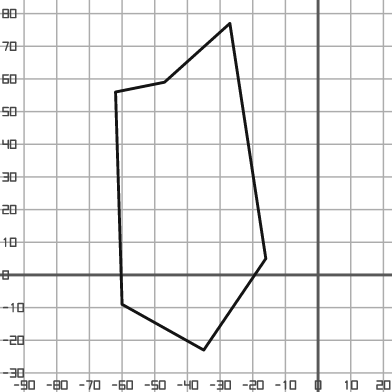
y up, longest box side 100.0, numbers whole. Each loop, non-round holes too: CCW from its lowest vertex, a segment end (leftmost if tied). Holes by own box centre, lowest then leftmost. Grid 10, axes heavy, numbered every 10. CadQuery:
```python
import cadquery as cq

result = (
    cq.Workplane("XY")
    .moveTo(-35.0, -23.0)
    .lineTo(-16.0, 5.0)
    .lineTo(-27.0, 77.0)
    .lineTo(-47.0, 59.0)
    .lineTo(-62.0, 56.0)
    .lineTo(-60.0, -9.0)
    .close()
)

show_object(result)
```